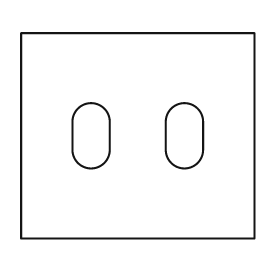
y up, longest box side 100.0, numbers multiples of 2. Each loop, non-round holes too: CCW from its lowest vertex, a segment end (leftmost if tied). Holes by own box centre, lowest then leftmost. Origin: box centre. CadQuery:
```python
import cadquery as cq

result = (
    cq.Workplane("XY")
    .moveTo(-50.0, -44.0)
    .lineTo(50.0, -44.0)
    .lineTo(50.0, 44.0)
    .lineTo(-50.0, 44.0)
    .close()
    .moveTo(-28.0, -6.0)
    .threePointArc((-20.0, -14.0), (-12.0, -6.0))
    .lineTo(-12.0, 6.0)
    .threePointArc((-20.0, 14.0), (-28.0, 6.0))
    .close()
    .moveTo(12.0, -6.0)
    .threePointArc((20.0, -14.0), (28.0, -6.0))
    .lineTo(28.0, 6.0)
    .threePointArc((20.0, 14.0), (12.0, 6.0))
    .close()
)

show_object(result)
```